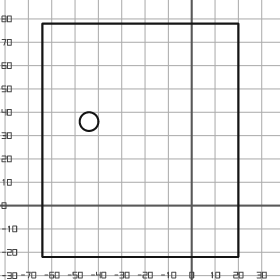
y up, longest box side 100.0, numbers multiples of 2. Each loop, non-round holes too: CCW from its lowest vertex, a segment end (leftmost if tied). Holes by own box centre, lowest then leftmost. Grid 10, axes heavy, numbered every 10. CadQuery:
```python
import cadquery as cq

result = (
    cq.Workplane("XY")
    .moveTo(-64.0, -22.0)
    .lineTo(20.0, -22.0)
    .lineTo(20.0, 78.0)
    .lineTo(-64.0, 78.0)
    .close()
    .moveTo(-44.0, 36.0)
    .circle(4.0)
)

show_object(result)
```